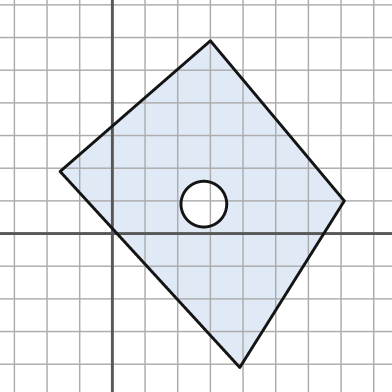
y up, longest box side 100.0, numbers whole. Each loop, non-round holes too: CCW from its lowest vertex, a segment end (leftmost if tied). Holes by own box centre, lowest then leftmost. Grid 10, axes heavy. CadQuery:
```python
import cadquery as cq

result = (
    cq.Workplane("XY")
    .moveTo(39.0, -41.0)
    .lineTo(71.0, 10.0)
    .lineTo(30.0, 59.0)
    .lineTo(-16.0, 19.0)
    .close()
    .moveTo(28.0, 9.0)
    .circle(7.0)
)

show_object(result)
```